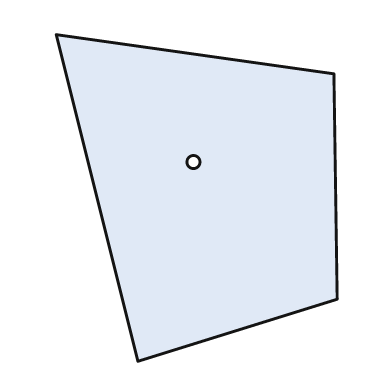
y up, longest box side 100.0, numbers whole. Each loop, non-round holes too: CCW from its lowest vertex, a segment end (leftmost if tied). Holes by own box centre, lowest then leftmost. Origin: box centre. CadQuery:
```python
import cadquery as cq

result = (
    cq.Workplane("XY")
    .moveTo(-18.0, -50.0)
    .lineTo(43.0, -31.0)
    .lineTo(42.0, 38.0)
    .lineTo(-43.0, 50.0)
    .close()
    .moveTo(-1.0, 11.0)
    .circle(2.0)
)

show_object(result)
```